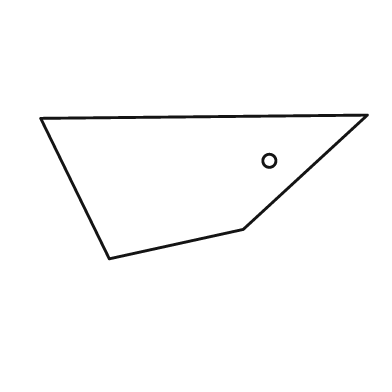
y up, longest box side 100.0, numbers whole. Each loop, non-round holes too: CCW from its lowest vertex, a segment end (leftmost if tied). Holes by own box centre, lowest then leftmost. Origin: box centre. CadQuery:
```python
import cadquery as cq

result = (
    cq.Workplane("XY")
    .moveTo(-29.0, -22.0)
    .lineTo(12.0, -13.0)
    .lineTo(50.0, 22.0)
    .lineTo(-50.0, 21.0)
    .close()
    .moveTo(20.0, 8.0)
    .circle(2.0)
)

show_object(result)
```